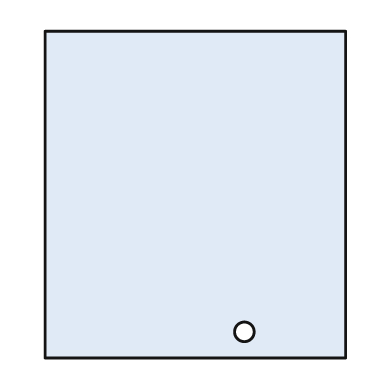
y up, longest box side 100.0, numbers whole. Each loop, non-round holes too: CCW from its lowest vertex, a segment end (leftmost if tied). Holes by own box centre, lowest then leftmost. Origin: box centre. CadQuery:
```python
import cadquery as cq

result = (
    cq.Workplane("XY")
    .moveTo(-46.0, -50.0)
    .lineTo(46.0, -50.0)
    .lineTo(46.0, 50.0)
    .lineTo(-46.0, 50.0)
    .close()
    .moveTo(15.0, -42.0)
    .circle(3.0)
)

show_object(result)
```